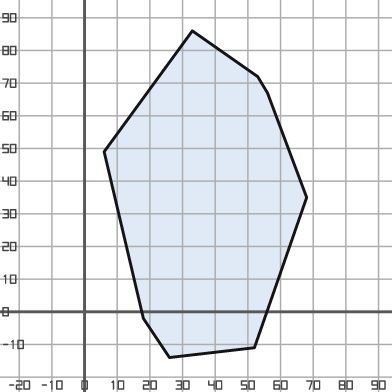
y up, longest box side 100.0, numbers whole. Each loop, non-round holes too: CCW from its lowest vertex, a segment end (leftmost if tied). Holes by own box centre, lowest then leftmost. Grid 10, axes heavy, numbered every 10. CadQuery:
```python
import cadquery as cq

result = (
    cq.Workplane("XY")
    .moveTo(26.0, -14.0)
    .lineTo(52.0, -11.0)
    .lineTo(68.0, 35.0)
    .lineTo(56.0, 67.0)
    .lineTo(53.0, 72.0)
    .lineTo(33.0, 86.0)
    .lineTo(6.0, 49.0)
    .lineTo(18.0, -2.0)
    .close()
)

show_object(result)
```